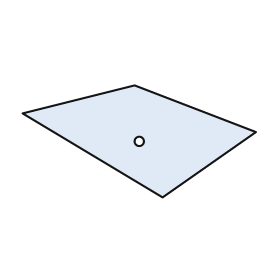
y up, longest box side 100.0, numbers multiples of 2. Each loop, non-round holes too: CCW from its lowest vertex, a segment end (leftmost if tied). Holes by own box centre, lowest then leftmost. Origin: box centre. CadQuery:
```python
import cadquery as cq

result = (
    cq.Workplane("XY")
    .moveTo(10.0, -24.0)
    .lineTo(50.0, 4.0)
    .lineTo(-2.0, 24.0)
    .lineTo(-50.0, 12.0)
    .close()
    .moveTo(0.0, 0.0)
    .circle(2.0)
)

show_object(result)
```